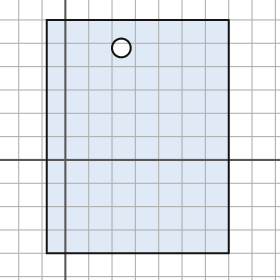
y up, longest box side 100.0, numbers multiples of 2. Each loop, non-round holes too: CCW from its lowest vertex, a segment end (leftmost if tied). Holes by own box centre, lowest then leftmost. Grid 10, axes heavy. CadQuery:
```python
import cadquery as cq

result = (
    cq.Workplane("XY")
    .moveTo(-8.0, -40.0)
    .lineTo(70.0, -40.0)
    .lineTo(70.0, 60.0)
    .lineTo(-8.0, 60.0)
    .close()
    .moveTo(24.0, 48.0)
    .circle(4.0)
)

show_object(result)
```